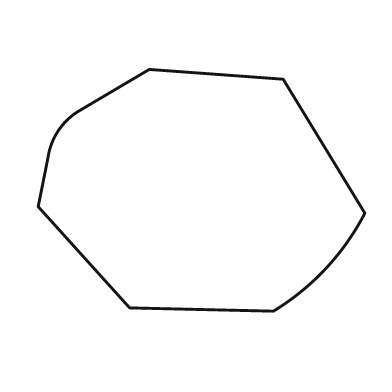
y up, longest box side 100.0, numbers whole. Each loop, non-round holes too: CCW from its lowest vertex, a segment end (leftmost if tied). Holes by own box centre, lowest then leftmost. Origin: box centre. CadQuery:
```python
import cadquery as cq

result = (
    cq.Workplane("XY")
    .moveTo(22.0, -37.0)
    .threePointArc((38.0, -24.0), (50.0, -7.0))
    .lineTo(25.0, 34.0)
    .lineTo(-16.0, 37.0)
    .lineTo(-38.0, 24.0)
    .threePointArc((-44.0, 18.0), (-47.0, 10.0))
    .lineTo(-50.0, -5.0)
    .lineTo(-22.0, -36.0)
    .close()
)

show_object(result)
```